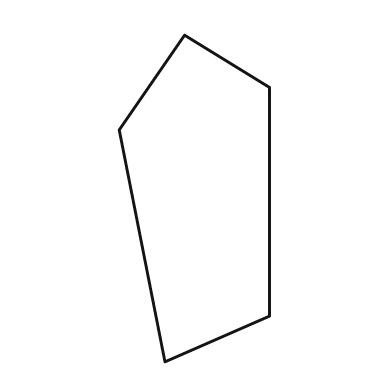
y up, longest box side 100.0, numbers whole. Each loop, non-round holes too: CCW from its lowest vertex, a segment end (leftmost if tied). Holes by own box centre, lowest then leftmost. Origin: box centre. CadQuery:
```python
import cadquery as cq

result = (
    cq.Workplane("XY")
    .moveTo(-9.0, -50.0)
    .lineTo(23.0, -36.0)
    .lineTo(23.0, 34.0)
    .lineTo(-3.0, 50.0)
    .lineTo(-23.0, 21.0)
    .close()
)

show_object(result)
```